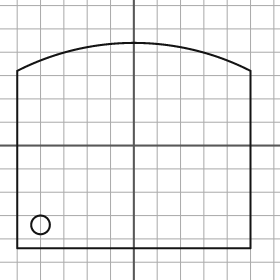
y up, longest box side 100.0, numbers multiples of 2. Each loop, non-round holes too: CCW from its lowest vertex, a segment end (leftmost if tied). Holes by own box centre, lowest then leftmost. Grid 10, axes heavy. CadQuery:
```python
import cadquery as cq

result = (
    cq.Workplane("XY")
    .moveTo(-50.0, -44.0)
    .lineTo(50.0, -44.0)
    .lineTo(50.0, 32.0)
    .threePointArc((0.0, 44.0), (-50.0, 32.0))
    .close()
    .moveTo(-40.0, -34.0)
    .circle(4.0)
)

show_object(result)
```